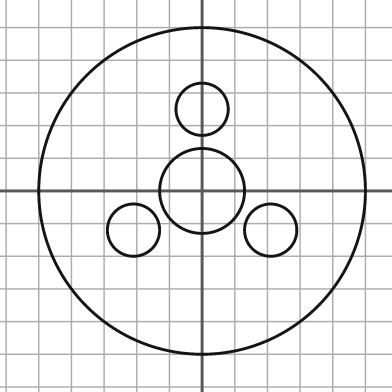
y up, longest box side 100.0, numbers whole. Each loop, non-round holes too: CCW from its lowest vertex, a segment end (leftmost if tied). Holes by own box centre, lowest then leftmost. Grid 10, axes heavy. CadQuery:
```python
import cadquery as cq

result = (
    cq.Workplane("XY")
    .moveTo(0.0, 0.0)
    .circle(50.0)
    .moveTo(-21.0, -12.0)
    .circle(8.0)
    .moveTo(21.0, -12.0)
    .circle(8.0)
    .moveTo(0.0, 0.0)
    .circle(13.0)
    .moveTo(0.0, 25.0)
    .circle(8.0)
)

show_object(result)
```